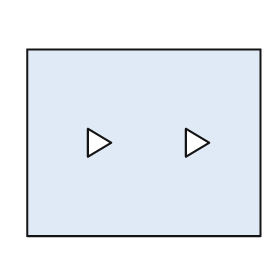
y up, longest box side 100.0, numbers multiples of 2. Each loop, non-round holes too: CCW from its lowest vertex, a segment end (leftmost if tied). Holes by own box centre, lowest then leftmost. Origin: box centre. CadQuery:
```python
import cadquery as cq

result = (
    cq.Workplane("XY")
    .moveTo(-50.0, -40.0)
    .lineTo(50.0, -40.0)
    .lineTo(50.0, 40.0)
    .lineTo(-50.0, 40.0)
    .close()
    .moveTo(-24.0, -6.0)
    .lineTo(-14.0, 0.0)
    .lineTo(-24.0, 6.0)
    .close()
    .moveTo(18.0, -6.0)
    .lineTo(28.0, 0.0)
    .lineTo(18.0, 6.0)
    .close()
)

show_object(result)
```